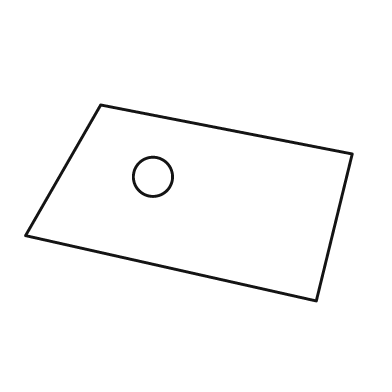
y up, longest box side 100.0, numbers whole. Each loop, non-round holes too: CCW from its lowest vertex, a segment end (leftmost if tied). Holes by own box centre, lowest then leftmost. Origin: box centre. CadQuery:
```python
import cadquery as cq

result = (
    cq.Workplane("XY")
    .moveTo(39.0, -30.0)
    .lineTo(50.0, 15.0)
    .lineTo(-27.0, 30.0)
    .lineTo(-50.0, -10.0)
    .close()
    .moveTo(-11.0, 8.0)
    .circle(6.0)
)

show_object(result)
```